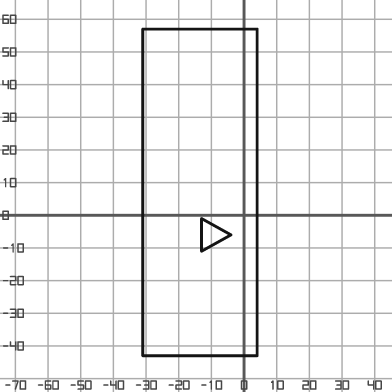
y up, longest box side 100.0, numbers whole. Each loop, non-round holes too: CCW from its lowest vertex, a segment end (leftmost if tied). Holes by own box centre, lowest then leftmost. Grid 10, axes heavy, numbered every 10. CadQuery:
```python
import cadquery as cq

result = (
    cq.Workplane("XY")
    .moveTo(-31.0, -43.0)
    .lineTo(4.0, -43.0)
    .lineTo(4.0, 57.0)
    .lineTo(-31.0, 57.0)
    .close()
    .moveTo(-13.0, -11.0)
    .lineTo(-4.0, -6.0)
    .lineTo(-13.0, -1.0)
    .close()
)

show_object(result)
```